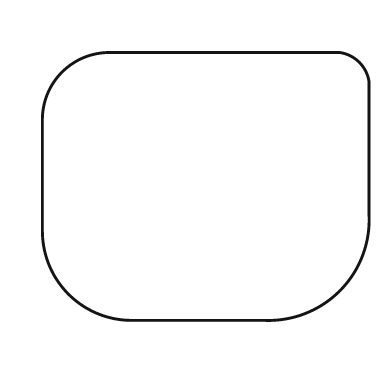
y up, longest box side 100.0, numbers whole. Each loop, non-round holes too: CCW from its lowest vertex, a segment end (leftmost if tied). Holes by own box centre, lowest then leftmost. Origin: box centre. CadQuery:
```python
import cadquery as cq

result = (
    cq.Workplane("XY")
    .moveTo(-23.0, -41.0)
    .lineTo(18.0, -41.0)
    .threePointArc((41.0, -32.0), (50.0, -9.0))
    .lineTo(50.0, 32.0)
    .threePointArc((47.0, 38.0), (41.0, 41.0))
    .lineTo(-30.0, 41.0)
    .threePointArc((-44.0, 35.0), (-50.0, 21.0))
    .lineTo(-50.0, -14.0)
    .threePointArc((-42.0, -33.0), (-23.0, -41.0))
    .close()
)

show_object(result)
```